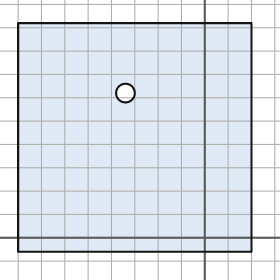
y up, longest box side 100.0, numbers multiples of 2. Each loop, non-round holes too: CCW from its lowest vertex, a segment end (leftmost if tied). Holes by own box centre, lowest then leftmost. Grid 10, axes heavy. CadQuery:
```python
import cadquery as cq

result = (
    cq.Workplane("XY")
    .moveTo(-80.0, -6.0)
    .lineTo(20.0, -6.0)
    .lineTo(20.0, 92.0)
    .lineTo(-80.0, 92.0)
    .close()
    .moveTo(-34.0, 62.0)
    .circle(4.0)
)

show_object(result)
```